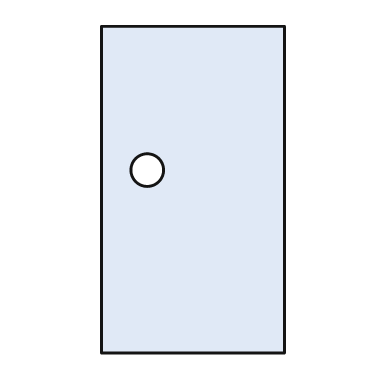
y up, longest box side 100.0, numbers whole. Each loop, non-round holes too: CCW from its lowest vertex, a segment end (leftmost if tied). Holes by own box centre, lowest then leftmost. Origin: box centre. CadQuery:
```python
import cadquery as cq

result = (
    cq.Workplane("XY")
    .moveTo(-28.0, -50.0)
    .lineTo(28.0, -50.0)
    .lineTo(28.0, 50.0)
    .lineTo(-28.0, 50.0)
    .close()
    .moveTo(-14.0, 6.0)
    .circle(5.0)
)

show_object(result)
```